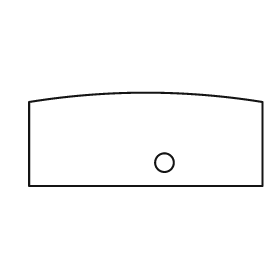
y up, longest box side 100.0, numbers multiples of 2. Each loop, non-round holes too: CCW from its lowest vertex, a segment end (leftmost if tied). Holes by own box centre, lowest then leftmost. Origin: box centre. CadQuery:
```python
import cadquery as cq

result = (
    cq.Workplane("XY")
    .moveTo(-50.0, -20.0)
    .lineTo(50.0, -20.0)
    .lineTo(50.0, 16.0)
    .threePointArc((0.0, 20.0), (-50.0, 16.0))
    .close()
    .moveTo(8.0, -10.0)
    .circle(4.0)
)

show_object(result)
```